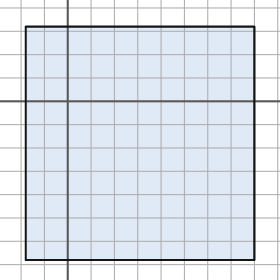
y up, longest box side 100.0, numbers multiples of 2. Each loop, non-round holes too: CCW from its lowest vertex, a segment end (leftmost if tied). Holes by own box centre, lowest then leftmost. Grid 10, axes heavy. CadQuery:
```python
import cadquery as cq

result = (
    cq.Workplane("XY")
    .moveTo(-18.0, -68.0)
    .lineTo(80.0, -68.0)
    .lineTo(80.0, 32.0)
    .lineTo(-18.0, 32.0)
    .close()
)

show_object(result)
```